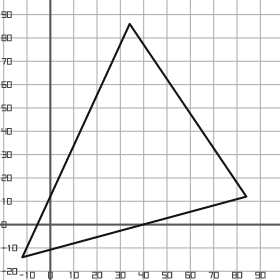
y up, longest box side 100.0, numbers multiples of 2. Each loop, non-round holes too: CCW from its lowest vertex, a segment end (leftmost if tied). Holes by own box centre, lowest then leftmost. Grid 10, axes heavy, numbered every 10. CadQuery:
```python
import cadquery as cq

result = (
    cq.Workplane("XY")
    .moveTo(-12.0, -14.0)
    .lineTo(84.0, 12.0)
    .lineTo(34.0, 86.0)
    .close()
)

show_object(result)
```